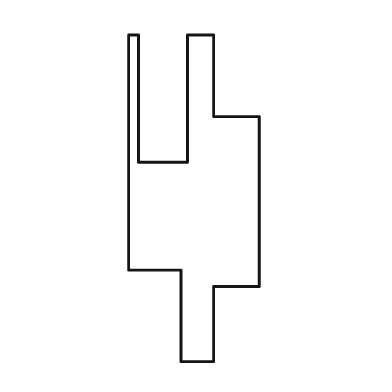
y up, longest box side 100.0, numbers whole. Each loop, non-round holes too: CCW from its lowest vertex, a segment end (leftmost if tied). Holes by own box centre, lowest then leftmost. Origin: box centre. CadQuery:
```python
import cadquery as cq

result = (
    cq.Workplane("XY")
    .moveTo(-4.0, -50.0)
    .lineTo(6.0, -50.0)
    .lineTo(6.0, -27.0)
    .lineTo(20.0, -27.0)
    .lineTo(20.0, 25.0)
    .lineTo(6.0, 25.0)
    .lineTo(6.0, 50.0)
    .lineTo(-2.0, 50.0)
    .lineTo(-2.0, 11.0)
    .lineTo(-17.0, 11.0)
    .lineTo(-17.0, 50.0)
    .lineTo(-20.0, 50.0)
    .lineTo(-20.0, -22.0)
    .lineTo(-4.0, -22.0)
    .close()
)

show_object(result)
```